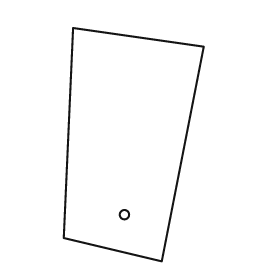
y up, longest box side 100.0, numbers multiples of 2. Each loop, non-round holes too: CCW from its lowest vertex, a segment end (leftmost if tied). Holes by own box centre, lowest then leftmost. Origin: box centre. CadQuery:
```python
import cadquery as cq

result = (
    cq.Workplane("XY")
    .moveTo(12.0, -50.0)
    .lineTo(30.0, 42.0)
    .lineTo(-26.0, 50.0)
    .lineTo(-30.0, -40.0)
    .close()
    .moveTo(-4.0, -30.0)
    .circle(2.0)
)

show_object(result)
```